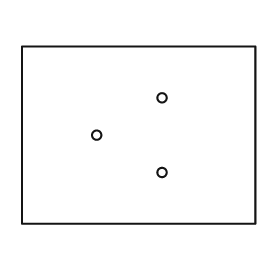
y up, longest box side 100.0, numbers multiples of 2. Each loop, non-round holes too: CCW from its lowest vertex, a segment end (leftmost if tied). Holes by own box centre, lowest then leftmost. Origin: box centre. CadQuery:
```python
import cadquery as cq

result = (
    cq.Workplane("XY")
    .moveTo(-50.0, -38.0)
    .lineTo(50.0, -38.0)
    .lineTo(50.0, 38.0)
    .lineTo(-50.0, 38.0)
    .close()
    .moveTo(10.0, -16.0)
    .circle(2.0)
    .moveTo(-18.0, 0.0)
    .circle(2.0)
    .moveTo(10.0, 16.0)
    .circle(2.0)
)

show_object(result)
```